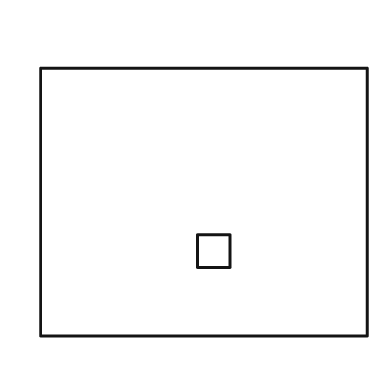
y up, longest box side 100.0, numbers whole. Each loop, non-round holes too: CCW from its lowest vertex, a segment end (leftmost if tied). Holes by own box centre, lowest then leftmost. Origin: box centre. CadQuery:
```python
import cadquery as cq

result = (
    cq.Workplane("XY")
    .moveTo(-50.0, -41.0)
    .lineTo(50.0, -41.0)
    .lineTo(50.0, 41.0)
    .lineTo(-50.0, 41.0)
    .close()
    .moveTo(-2.0, -20.0)
    .lineTo(8.0, -20.0)
    .lineTo(8.0, -10.0)
    .lineTo(-2.0, -10.0)
    .close()
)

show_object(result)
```